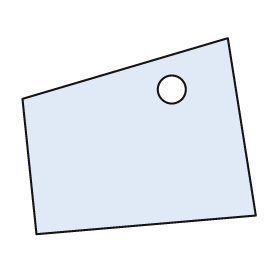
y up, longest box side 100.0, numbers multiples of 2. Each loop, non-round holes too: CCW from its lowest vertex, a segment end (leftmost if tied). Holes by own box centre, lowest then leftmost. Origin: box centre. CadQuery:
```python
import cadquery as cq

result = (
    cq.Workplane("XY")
    .moveTo(-44.0, -42.0)
    .lineTo(50.0, -34.0)
    .lineTo(38.0, 42.0)
    .lineTo(-50.0, 16.0)
    .close()
    .moveTo(14.0, 20.0)
    .circle(6.0)
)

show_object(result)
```